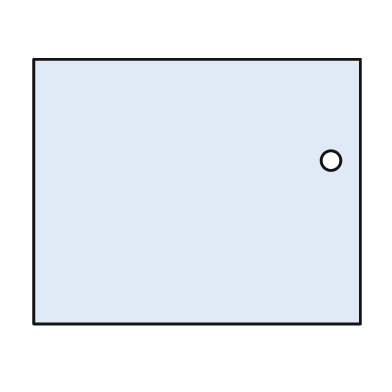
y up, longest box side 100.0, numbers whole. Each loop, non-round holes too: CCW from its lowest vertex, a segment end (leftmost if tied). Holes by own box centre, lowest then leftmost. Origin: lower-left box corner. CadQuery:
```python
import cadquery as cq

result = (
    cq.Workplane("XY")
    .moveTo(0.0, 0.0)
    .lineTo(100.0, 0.0)
    .lineTo(100.0, 81.0)
    .lineTo(0.0, 81.0)
    .close()
    .moveTo(91.0, 50.0)
    .circle(3.0)
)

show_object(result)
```